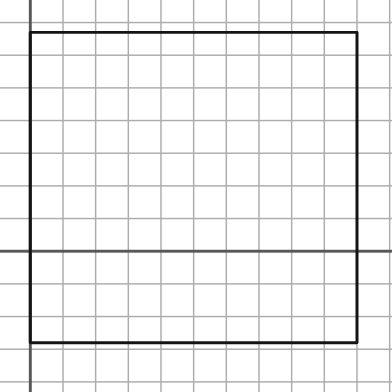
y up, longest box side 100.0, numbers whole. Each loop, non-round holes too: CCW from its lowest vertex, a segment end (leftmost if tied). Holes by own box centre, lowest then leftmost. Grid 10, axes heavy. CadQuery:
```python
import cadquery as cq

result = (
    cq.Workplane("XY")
    .moveTo(0.0, -28.0)
    .lineTo(100.0, -28.0)
    .lineTo(100.0, 67.0)
    .lineTo(0.0, 67.0)
    .close()
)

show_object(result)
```